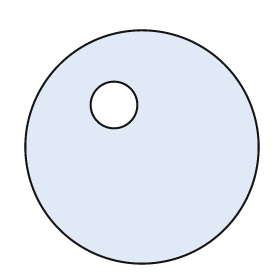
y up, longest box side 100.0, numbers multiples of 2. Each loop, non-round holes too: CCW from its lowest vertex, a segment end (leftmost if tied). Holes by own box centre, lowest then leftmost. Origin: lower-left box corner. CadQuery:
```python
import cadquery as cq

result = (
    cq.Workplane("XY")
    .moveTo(50.0, 50.0)
    .circle(50.0)
    .moveTo(38.0, 68.0)
    .circle(10.0)
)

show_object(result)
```